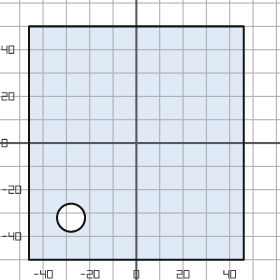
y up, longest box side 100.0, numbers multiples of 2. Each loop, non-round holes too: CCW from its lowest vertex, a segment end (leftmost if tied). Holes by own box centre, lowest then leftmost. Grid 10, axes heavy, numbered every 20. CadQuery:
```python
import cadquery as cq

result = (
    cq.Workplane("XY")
    .moveTo(-46.0, -50.0)
    .lineTo(46.0, -50.0)
    .lineTo(46.0, 50.0)
    .lineTo(-46.0, 50.0)
    .close()
    .moveTo(-28.0, -32.0)
    .circle(6.0)
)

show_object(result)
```